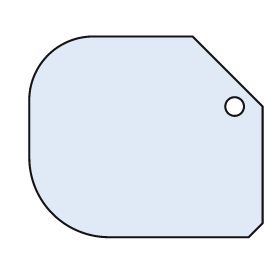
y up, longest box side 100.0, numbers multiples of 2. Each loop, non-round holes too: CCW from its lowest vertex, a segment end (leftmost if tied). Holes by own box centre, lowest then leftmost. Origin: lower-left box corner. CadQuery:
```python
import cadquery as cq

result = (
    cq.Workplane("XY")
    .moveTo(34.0, 0.0)
    .lineTo(94.0, 0.0)
    .lineTo(100.0, 6.0)
    .lineTo(100.0, 56.0)
    .lineTo(70.0, 86.0)
    .lineTo(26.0, 86.0)
    .threePointArc((8.0, 78.0), (0.0, 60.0))
    .lineTo(0.0, 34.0)
    .threePointArc((10.0, 10.0), (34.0, 0.0))
    .close()
    .moveTo(88.0, 56.0)
    .circle(4.0)
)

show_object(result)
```